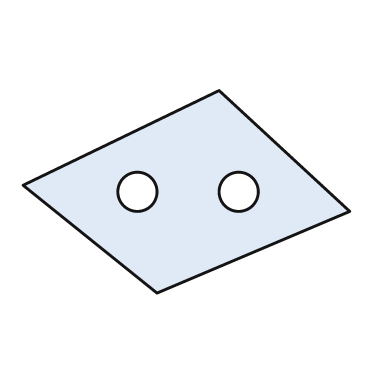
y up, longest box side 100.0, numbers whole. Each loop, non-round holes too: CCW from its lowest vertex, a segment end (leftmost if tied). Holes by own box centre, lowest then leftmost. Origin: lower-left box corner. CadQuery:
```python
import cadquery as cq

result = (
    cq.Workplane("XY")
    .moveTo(41.0, 0.0)
    .lineTo(100.0, 25.0)
    .lineTo(60.0, 62.0)
    .lineTo(0.0, 33.0)
    .close()
    .moveTo(35.0, 31.0)
    .circle(6.0)
    .moveTo(66.0, 31.0)
    .circle(6.0)
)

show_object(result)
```